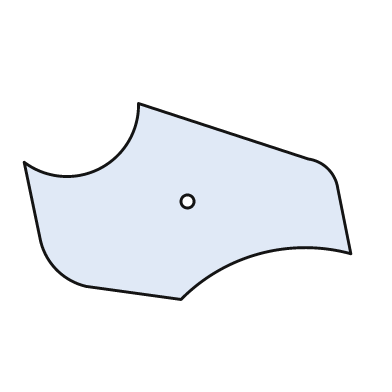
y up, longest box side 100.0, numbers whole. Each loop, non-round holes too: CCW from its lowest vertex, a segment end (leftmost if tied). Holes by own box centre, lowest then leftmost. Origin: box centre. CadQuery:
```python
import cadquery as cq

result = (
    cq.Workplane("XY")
    .moveTo(-2.0, -30.0)
    .threePointArc((22.0, -16.0), (50.0, -16.0))
    .lineTo(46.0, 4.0)
    .threePointArc((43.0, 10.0), (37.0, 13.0))
    .lineTo(-15.0, 30.0)
    .threePointArc((-27.0, 10.0), (-50.0, 12.0))
    .lineTo(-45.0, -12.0)
    .threePointArc((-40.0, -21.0), (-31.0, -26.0))
    .close()
    .moveTo(0.0, 0.0)
    .circle(2.0)
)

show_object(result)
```